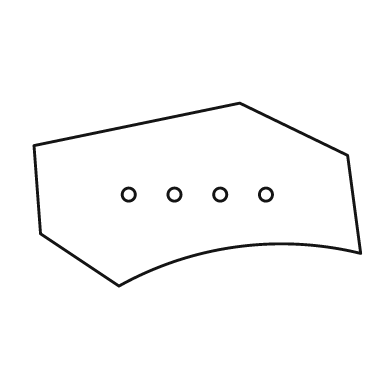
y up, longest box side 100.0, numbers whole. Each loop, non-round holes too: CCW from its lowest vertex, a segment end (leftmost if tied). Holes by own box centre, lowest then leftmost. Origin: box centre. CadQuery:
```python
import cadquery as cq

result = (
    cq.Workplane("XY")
    .moveTo(-24.0, -28.0)
    .threePointArc((12.0, -16.0), (50.0, -18.0))
    .lineTo(46.0, 12.0)
    .lineTo(13.0, 28.0)
    .lineTo(-50.0, 15.0)
    .lineTo(-48.0, -12.0)
    .close()
    .moveTo(-21.0, 0.0)
    .circle(2.0)
    .moveTo(-7.0, 0.0)
    .circle(2.0)
    .moveTo(7.0, 0.0)
    .circle(2.0)
    .moveTo(21.0, 0.0)
    .circle(2.0)
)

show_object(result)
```